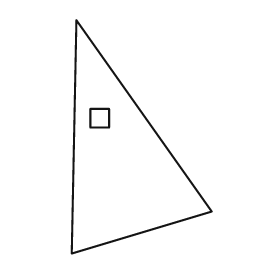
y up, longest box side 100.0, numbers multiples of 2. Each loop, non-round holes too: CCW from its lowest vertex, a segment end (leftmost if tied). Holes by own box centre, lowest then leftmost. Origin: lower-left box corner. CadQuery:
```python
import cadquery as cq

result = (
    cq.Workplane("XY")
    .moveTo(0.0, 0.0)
    .lineTo(60.0, 18.0)
    .lineTo(2.0, 100.0)
    .close()
    .moveTo(8.0, 54.0)
    .lineTo(16.0, 54.0)
    .lineTo(16.0, 62.0)
    .lineTo(8.0, 62.0)
    .close()
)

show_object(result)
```